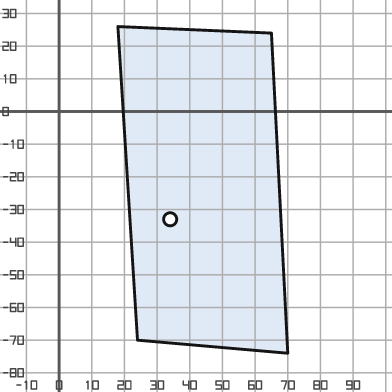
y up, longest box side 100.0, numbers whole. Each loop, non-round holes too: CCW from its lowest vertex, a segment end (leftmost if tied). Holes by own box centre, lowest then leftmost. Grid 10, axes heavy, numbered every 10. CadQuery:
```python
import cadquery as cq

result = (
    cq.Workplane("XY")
    .moveTo(70.0, -74.0)
    .lineTo(65.0, 24.0)
    .lineTo(18.0, 26.0)
    .lineTo(24.0, -70.0)
    .close()
    .moveTo(34.0, -33.0)
    .circle(2.0)
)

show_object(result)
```